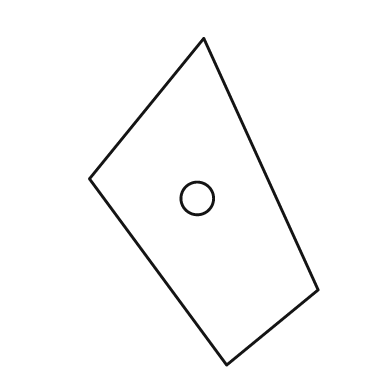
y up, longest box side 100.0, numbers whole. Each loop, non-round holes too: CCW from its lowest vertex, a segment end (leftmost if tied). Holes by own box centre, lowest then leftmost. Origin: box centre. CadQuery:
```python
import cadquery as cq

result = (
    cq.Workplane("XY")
    .moveTo(7.0, -50.0)
    .lineTo(35.0, -27.0)
    .lineTo(0.0, 50.0)
    .lineTo(-35.0, 7.0)
    .close()
    .moveTo(-2.0, 1.0)
    .circle(5.0)
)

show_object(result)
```